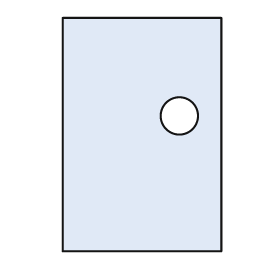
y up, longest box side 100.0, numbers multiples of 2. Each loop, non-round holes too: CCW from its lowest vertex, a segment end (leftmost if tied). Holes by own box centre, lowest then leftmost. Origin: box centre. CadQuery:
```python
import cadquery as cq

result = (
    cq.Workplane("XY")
    .moveTo(-34.0, -50.0)
    .lineTo(34.0, -50.0)
    .lineTo(34.0, 50.0)
    .lineTo(-34.0, 50.0)
    .close()
    .moveTo(16.0, 8.0)
    .circle(8.0)
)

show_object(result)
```